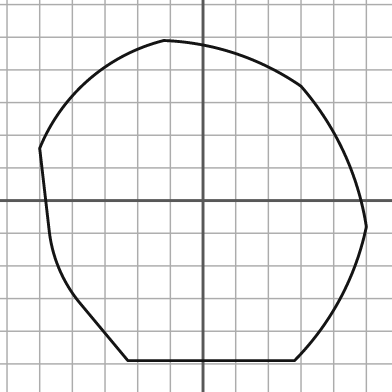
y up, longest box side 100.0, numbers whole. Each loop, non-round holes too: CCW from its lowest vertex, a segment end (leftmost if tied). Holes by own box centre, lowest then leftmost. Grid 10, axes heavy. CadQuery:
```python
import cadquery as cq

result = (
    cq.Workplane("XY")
    .moveTo(-23.0, -49.0)
    .lineTo(28.0, -49.0)
    .threePointArc((42.0, -30.0), (50.0, -8.0))
    .threePointArc((43.0, 15.0), (30.0, 35.0))
    .threePointArc((10.0, 45.0), (-12.0, 49.0))
    .threePointArc((-35.0, 37.0), (-50.0, 16.0))
    .lineTo(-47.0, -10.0)
    .threePointArc((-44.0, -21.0), (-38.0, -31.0))
    .close()
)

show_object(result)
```